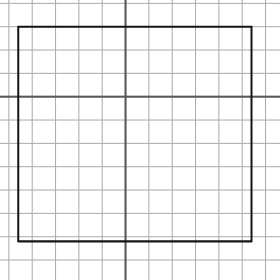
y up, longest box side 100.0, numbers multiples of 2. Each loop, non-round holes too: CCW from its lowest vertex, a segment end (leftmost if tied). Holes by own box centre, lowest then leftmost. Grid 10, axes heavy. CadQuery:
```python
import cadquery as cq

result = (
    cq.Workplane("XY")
    .moveTo(-46.0, -62.0)
    .lineTo(54.0, -62.0)
    .lineTo(54.0, 30.0)
    .lineTo(-46.0, 30.0)
    .close()
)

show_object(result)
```